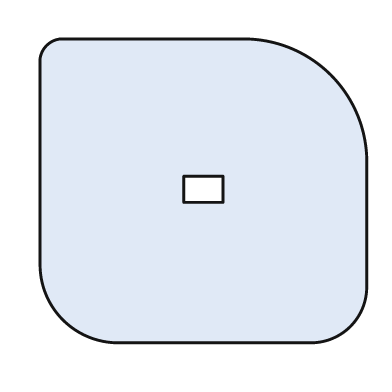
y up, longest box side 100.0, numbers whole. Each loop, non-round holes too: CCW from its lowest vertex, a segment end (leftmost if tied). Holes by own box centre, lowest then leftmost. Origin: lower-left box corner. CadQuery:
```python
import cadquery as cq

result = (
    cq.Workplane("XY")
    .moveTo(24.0, 0.0)
    .lineTo(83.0, 0.0)
    .threePointArc((95.0, 5.0), (100.0, 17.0))
    .lineTo(100.0, 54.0)
    .threePointArc((89.0, 82.0), (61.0, 93.0))
    .lineTo(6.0, 93.0)
    .threePointArc((2.0, 91.0), (0.0, 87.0))
    .lineTo(0.0, 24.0)
    .threePointArc((7.0, 7.0), (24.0, 0.0))
    .close()
    .moveTo(44.0, 43.0)
    .lineTo(56.0, 43.0)
    .lineTo(56.0, 51.0)
    .lineTo(44.0, 51.0)
    .close()
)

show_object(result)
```